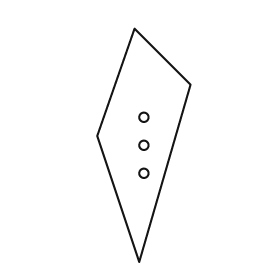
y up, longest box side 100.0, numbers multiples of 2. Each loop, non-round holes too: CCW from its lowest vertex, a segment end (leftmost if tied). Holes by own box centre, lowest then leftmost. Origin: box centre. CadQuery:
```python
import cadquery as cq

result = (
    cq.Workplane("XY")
    .moveTo(-2.0, -50.0)
    .lineTo(20.0, 26.0)
    .lineTo(-4.0, 50.0)
    .lineTo(-20.0, 4.0)
    .close()
    .moveTo(0.0, -12.0)
    .circle(2.0)
    .moveTo(0.0, 0.0)
    .circle(2.0)
    .moveTo(0.0, 12.0)
    .circle(2.0)
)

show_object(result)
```